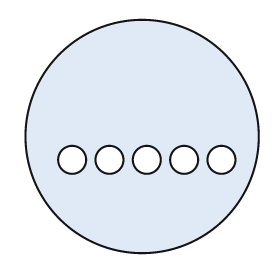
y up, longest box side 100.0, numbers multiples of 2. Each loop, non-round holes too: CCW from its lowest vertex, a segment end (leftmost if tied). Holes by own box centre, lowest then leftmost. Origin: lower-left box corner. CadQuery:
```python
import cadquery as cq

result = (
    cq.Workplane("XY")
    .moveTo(50.0, 50.0)
    .circle(50.0)
    .moveTo(20.0, 40.0)
    .circle(6.0)
    .moveTo(36.0, 40.0)
    .circle(6.0)
    .moveTo(52.0, 40.0)
    .circle(6.0)
    .moveTo(68.0, 40.0)
    .circle(6.0)
    .moveTo(84.0, 40.0)
    .circle(6.0)
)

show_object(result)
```